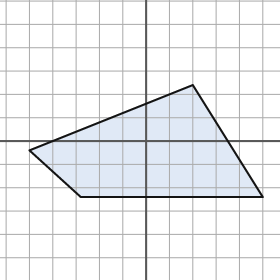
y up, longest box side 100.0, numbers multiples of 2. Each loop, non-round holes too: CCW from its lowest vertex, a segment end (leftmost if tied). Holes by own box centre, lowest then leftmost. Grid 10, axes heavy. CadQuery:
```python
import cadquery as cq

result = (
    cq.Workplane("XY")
    .moveTo(-28.0, -24.0)
    .lineTo(50.0, -24.0)
    .lineTo(20.0, 24.0)
    .lineTo(-50.0, -4.0)
    .close()
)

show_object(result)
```